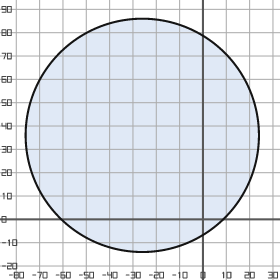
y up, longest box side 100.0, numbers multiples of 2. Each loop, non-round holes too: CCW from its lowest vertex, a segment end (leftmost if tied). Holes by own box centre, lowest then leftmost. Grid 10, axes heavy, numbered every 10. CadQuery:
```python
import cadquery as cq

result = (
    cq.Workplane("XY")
    .moveTo(-26.0, 36.0)
    .circle(50.0)
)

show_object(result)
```